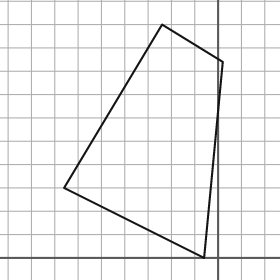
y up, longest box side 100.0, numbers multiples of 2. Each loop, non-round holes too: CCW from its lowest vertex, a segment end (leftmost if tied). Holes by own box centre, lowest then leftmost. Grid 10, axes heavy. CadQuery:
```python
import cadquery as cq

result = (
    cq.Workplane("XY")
    .moveTo(-6.0, 0.0)
    .lineTo(2.0, 84.0)
    .lineTo(-24.0, 100.0)
    .lineTo(-66.0, 30.0)
    .close()
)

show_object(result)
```